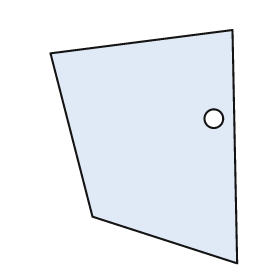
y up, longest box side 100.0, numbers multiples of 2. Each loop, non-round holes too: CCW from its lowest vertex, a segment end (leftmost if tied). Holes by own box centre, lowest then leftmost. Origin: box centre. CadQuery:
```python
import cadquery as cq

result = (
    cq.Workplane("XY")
    .moveTo(40.0, -50.0)
    .lineTo(38.0, 50.0)
    .lineTo(-40.0, 40.0)
    .lineTo(-22.0, -30.0)
    .close()
    .moveTo(30.0, 12.0)
    .circle(4.0)
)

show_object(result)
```